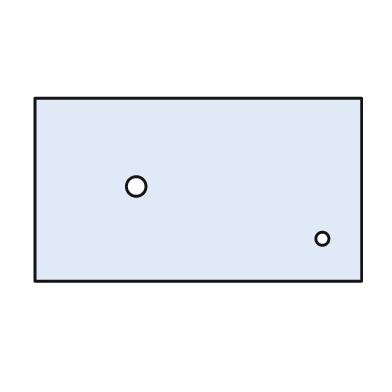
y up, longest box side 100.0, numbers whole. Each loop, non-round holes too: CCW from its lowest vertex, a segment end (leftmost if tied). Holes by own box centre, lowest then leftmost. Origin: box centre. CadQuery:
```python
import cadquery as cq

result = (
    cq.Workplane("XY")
    .moveTo(-50.0, -28.0)
    .lineTo(50.0, -28.0)
    .lineTo(50.0, 28.0)
    .lineTo(-50.0, 28.0)
    .close()
    .moveTo(38.0, -15.0)
    .circle(2.0)
    .moveTo(-19.0, 1.0)
    .circle(3.0)
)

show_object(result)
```